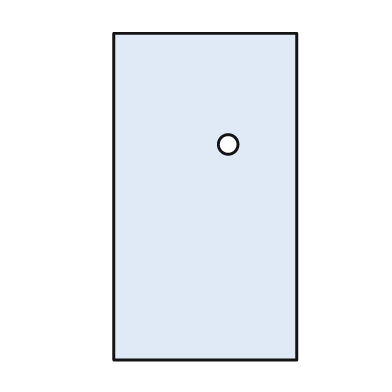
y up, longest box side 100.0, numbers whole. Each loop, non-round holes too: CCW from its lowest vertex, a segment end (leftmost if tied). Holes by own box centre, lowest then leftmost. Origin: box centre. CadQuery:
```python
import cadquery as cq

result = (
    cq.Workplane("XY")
    .moveTo(-28.0, -50.0)
    .lineTo(28.0, -50.0)
    .lineTo(28.0, 50.0)
    .lineTo(-28.0, 50.0)
    .close()
    .moveTo(7.0, 16.0)
    .circle(3.0)
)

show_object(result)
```